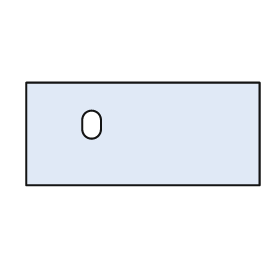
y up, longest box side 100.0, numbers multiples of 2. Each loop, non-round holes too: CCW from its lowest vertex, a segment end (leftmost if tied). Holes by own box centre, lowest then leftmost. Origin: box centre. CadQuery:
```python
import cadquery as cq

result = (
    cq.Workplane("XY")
    .moveTo(-50.0, -22.0)
    .lineTo(50.0, -22.0)
    .lineTo(50.0, 22.0)
    .lineTo(-50.0, 22.0)
    .close()
    .moveTo(-26.0, 2.0)
    .threePointArc((-22.0, -2.0), (-18.0, 2.0))
    .lineTo(-18.0, 6.0)
    .threePointArc((-22.0, 10.0), (-26.0, 6.0))
    .close()
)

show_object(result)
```